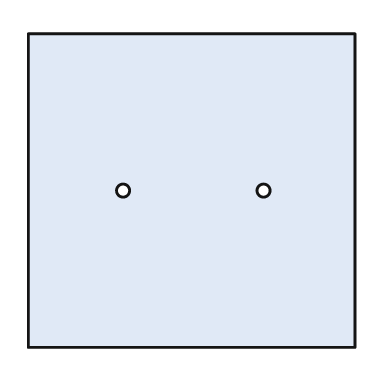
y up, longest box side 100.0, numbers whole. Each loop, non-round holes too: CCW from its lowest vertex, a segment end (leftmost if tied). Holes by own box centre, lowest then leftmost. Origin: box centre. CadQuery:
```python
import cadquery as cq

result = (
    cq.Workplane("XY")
    .moveTo(-50.0, -48.0)
    .lineTo(50.0, -48.0)
    .lineTo(50.0, 48.0)
    .lineTo(-50.0, 48.0)
    .close()
    .moveTo(-21.0, 0.0)
    .circle(2.0)
    .moveTo(22.0, 0.0)
    .circle(2.0)
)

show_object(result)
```